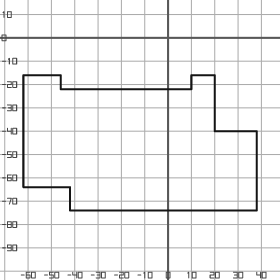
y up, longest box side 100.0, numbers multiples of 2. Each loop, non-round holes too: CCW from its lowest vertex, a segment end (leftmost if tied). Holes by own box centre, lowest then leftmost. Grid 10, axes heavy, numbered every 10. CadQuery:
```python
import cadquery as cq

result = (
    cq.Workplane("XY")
    .moveTo(-42.0, -74.0)
    .lineTo(38.0, -74.0)
    .lineTo(38.0, -40.0)
    .lineTo(20.0, -40.0)
    .lineTo(20.0, -16.0)
    .lineTo(10.0, -16.0)
    .lineTo(10.0, -22.0)
    .lineTo(-46.0, -22.0)
    .lineTo(-46.0, -16.0)
    .lineTo(-62.0, -16.0)
    .lineTo(-62.0, -64.0)
    .lineTo(-42.0, -64.0)
    .close()
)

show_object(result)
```